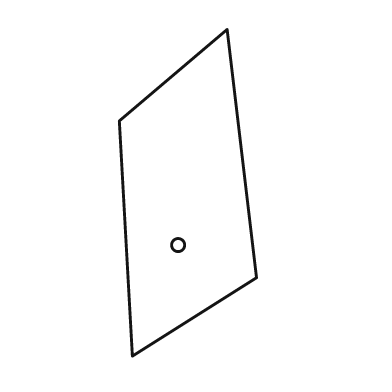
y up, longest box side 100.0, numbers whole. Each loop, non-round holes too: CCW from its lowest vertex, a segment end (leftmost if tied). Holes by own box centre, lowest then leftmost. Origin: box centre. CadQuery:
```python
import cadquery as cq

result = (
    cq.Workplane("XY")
    .moveTo(-17.0, -50.0)
    .lineTo(21.0, -26.0)
    .lineTo(12.0, 50.0)
    .lineTo(-21.0, 22.0)
    .close()
    .moveTo(-3.0, -16.0)
    .circle(2.0)
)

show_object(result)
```